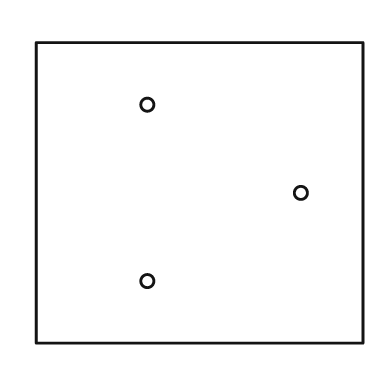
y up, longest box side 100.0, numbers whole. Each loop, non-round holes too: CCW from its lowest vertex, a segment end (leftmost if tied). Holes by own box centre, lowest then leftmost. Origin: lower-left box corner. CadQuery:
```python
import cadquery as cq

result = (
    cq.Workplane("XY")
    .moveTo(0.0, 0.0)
    .lineTo(100.0, 0.0)
    .lineTo(100.0, 92.0)
    .lineTo(0.0, 92.0)
    .close()
    .moveTo(34.0, 19.0)
    .circle(2.0)
    .moveTo(81.0, 46.0)
    .circle(2.0)
    .moveTo(34.0, 73.0)
    .circle(2.0)
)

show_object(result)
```